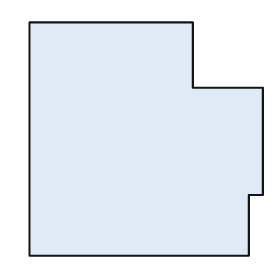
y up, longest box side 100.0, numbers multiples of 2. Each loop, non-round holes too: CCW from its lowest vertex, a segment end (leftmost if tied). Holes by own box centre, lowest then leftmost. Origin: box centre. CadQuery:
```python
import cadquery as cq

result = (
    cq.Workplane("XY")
    .moveTo(-50.0, -50.0)
    .lineTo(44.0, -50.0)
    .lineTo(44.0, -24.0)
    .lineTo(50.0, -24.0)
    .lineTo(50.0, 22.0)
    .lineTo(20.0, 22.0)
    .lineTo(20.0, 50.0)
    .lineTo(-50.0, 50.0)
    .close()
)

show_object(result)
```